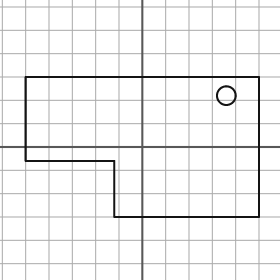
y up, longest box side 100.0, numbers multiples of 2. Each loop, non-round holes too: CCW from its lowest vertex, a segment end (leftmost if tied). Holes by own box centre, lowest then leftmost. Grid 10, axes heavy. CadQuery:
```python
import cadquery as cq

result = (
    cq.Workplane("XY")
    .moveTo(-12.0, -30.0)
    .lineTo(50.0, -30.0)
    .lineTo(50.0, 30.0)
    .lineTo(-50.0, 30.0)
    .lineTo(-50.0, -6.0)
    .lineTo(-12.0, -6.0)
    .close()
    .moveTo(36.0, 22.0)
    .circle(4.0)
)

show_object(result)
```